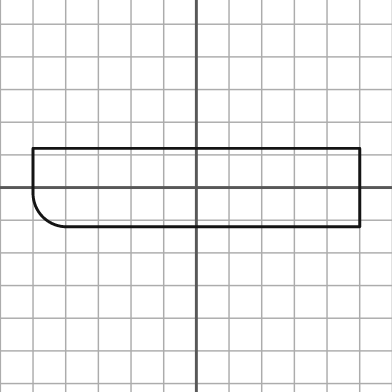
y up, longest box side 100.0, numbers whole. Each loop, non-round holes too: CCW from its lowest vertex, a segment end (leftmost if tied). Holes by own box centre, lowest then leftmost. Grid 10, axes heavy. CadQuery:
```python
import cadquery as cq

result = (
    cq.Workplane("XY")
    .moveTo(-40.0, -12.0)
    .lineTo(50.0, -12.0)
    .lineTo(50.0, 12.0)
    .lineTo(-50.0, 12.0)
    .lineTo(-50.0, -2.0)
    .threePointArc((-47.0, -9.0), (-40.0, -12.0))
    .close()
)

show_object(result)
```